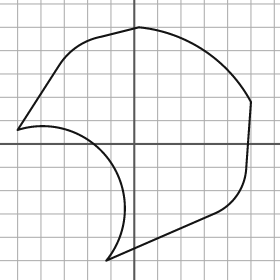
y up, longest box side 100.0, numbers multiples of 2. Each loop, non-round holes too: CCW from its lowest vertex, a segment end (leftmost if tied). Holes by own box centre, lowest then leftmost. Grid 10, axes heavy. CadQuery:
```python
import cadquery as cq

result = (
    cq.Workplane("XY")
    .moveTo(-12.0, -50.0)
    .lineTo(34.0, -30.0)
    .threePointArc((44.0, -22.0), (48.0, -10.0))
    .lineTo(50.0, 18.0)
    .threePointArc((30.0, 40.0), (2.0, 50.0))
    .lineTo(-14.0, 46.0)
    .threePointArc((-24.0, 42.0), (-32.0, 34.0))
    .lineTo(-50.0, 6.0)
    .threePointArc((-10.0, -8.0), (-12.0, -50.0))
    .close()
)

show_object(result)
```